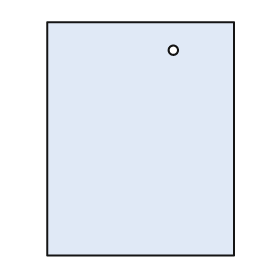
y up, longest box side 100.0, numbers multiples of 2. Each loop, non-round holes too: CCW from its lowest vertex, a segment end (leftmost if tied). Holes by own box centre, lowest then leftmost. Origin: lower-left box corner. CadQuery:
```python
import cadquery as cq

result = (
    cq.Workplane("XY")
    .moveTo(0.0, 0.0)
    .lineTo(80.0, 0.0)
    .lineTo(80.0, 100.0)
    .lineTo(0.0, 100.0)
    .close()
    .moveTo(54.0, 88.0)
    .circle(2.0)
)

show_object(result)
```